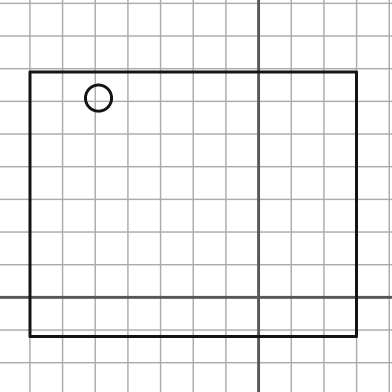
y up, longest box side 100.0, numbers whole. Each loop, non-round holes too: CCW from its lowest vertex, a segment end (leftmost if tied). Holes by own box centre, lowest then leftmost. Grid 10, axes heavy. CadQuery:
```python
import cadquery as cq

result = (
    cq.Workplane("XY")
    .moveTo(-70.0, -12.0)
    .lineTo(30.0, -12.0)
    .lineTo(30.0, 69.0)
    .lineTo(-70.0, 69.0)
    .close()
    .moveTo(-49.0, 61.0)
    .circle(4.0)
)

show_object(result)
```